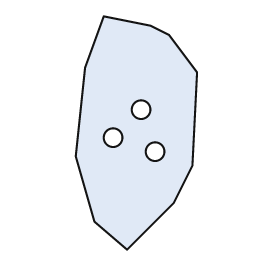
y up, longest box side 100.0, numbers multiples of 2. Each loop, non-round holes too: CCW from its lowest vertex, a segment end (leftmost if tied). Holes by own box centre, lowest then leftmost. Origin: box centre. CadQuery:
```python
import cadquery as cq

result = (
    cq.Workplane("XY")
    .moveTo(-4.0, -50.0)
    .lineTo(16.0, -30.0)
    .lineTo(24.0, -14.0)
    .lineTo(26.0, 26.0)
    .lineTo(14.0, 42.0)
    .lineTo(6.0, 46.0)
    .lineTo(-14.0, 50.0)
    .lineTo(-22.0, 28.0)
    .lineTo(-26.0, -10.0)
    .lineTo(-18.0, -38.0)
    .close()
    .moveTo(8.0, -8.0)
    .circle(4.0)
    .moveTo(-10.0, -2.0)
    .circle(4.0)
    .moveTo(2.0, 10.0)
    .circle(4.0)
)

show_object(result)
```